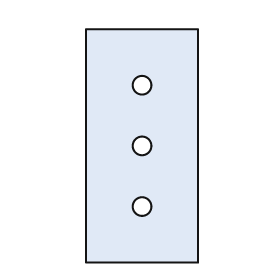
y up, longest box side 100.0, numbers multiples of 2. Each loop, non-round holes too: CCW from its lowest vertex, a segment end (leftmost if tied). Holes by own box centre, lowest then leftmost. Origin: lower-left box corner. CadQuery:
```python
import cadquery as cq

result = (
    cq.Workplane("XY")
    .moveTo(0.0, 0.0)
    .lineTo(48.0, 0.0)
    .lineTo(48.0, 100.0)
    .lineTo(0.0, 100.0)
    .close()
    .moveTo(24.0, 24.0)
    .circle(4.0)
    .moveTo(24.0, 50.0)
    .circle(4.0)
    .moveTo(24.0, 76.0)
    .circle(4.0)
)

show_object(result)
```